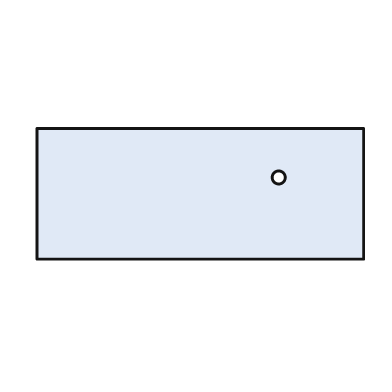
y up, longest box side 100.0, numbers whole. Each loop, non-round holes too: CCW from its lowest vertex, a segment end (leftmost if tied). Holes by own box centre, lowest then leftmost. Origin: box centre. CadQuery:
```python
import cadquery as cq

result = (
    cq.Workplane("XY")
    .moveTo(-50.0, -20.0)
    .lineTo(50.0, -20.0)
    .lineTo(50.0, 20.0)
    .lineTo(-50.0, 20.0)
    .close()
    .moveTo(24.0, 5.0)
    .circle(2.0)
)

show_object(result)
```